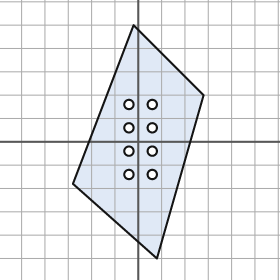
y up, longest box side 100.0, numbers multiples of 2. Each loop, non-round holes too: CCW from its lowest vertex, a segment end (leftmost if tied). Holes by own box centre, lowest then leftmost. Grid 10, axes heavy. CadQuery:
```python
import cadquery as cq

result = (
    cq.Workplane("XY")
    .moveTo(8.0, -50.0)
    .lineTo(28.0, 20.0)
    .lineTo(-2.0, 50.0)
    .lineTo(-28.0, -18.0)
    .close()
    .moveTo(-4.0, -14.0)
    .circle(2.0)
    .moveTo(6.0, -14.0)
    .circle(2.0)
    .moveTo(-4.0, -4.0)
    .circle(2.0)
    .moveTo(6.0, -4.0)
    .circle(2.0)
    .moveTo(-4.0, 6.0)
    .circle(2.0)
    .moveTo(6.0, 6.0)
    .circle(2.0)
    .moveTo(-4.0, 16.0)
    .circle(2.0)
    .moveTo(6.0, 16.0)
    .circle(2.0)
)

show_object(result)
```